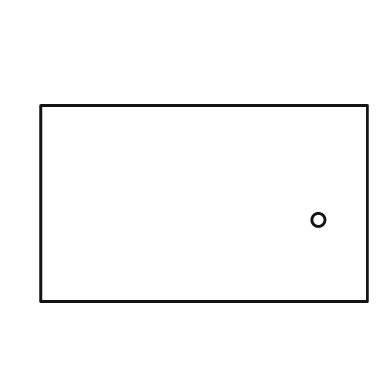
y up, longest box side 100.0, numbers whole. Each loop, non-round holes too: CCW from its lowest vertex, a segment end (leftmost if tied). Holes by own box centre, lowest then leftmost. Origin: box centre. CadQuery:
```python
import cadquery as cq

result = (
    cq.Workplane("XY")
    .moveTo(-50.0, -30.0)
    .lineTo(50.0, -30.0)
    .lineTo(50.0, 30.0)
    .lineTo(-50.0, 30.0)
    .close()
    .moveTo(35.0, -5.0)
    .circle(2.0)
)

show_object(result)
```